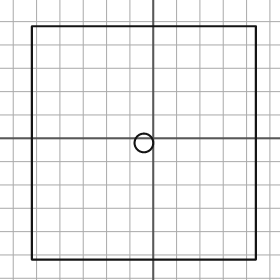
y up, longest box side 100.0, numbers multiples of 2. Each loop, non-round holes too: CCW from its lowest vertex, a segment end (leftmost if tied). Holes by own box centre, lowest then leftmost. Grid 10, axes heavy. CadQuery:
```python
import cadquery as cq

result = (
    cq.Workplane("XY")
    .moveTo(-52.0, -52.0)
    .lineTo(44.0, -52.0)
    .lineTo(44.0, 48.0)
    .lineTo(-52.0, 48.0)
    .close()
    .moveTo(-4.0, -2.0)
    .circle(4.0)
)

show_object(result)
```